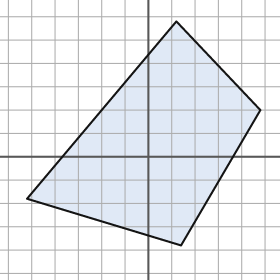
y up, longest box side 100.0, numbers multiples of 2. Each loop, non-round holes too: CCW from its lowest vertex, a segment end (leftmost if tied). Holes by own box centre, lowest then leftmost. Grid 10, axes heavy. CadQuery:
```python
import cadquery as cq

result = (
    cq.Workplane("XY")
    .moveTo(14.0, -38.0)
    .lineTo(48.0, 20.0)
    .lineTo(12.0, 58.0)
    .lineTo(-52.0, -18.0)
    .close()
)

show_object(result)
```